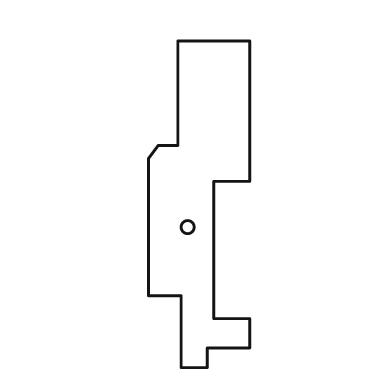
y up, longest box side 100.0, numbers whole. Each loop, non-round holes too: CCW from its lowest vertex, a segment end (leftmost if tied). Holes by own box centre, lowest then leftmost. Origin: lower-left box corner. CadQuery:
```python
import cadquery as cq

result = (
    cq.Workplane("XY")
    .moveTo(10.0, 0.0)
    .lineTo(18.0, 0.0)
    .lineTo(18.0, 6.0)
    .lineTo(31.0, 6.0)
    .lineTo(31.0, 15.0)
    .lineTo(20.0, 15.0)
    .lineTo(20.0, 57.0)
    .lineTo(31.0, 57.0)
    .lineTo(31.0, 100.0)
    .lineTo(9.0, 100.0)
    .lineTo(9.0, 68.0)
    .lineTo(3.0, 68.0)
    .lineTo(0.0, 64.0)
    .lineTo(0.0, 22.0)
    .lineTo(10.0, 22.0)
    .close()
    .moveTo(12.0, 43.0)
    .circle(2.0)
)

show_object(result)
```